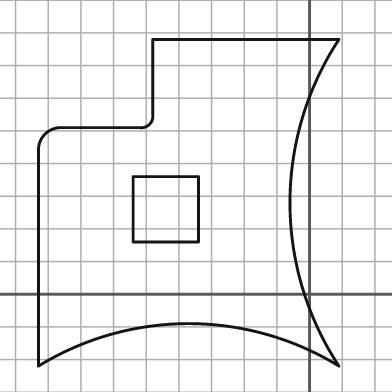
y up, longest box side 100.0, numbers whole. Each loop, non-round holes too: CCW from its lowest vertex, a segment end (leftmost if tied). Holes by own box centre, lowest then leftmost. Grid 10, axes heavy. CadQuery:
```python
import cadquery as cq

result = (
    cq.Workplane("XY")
    .moveTo(-83.0, -22.0)
    .threePointArc((-37.0, -9.0), (9.0, -22.0))
    .threePointArc((-6.0, 28.0), (9.0, 78.0))
    .lineTo(-48.0, 78.0)
    .lineTo(-48.0, 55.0)
    .threePointArc((-49.0, 52.0), (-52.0, 51.0))
    .lineTo(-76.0, 51.0)
    .threePointArc((-81.0, 49.0), (-83.0, 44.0))
    .close()
    .moveTo(-54.0, 16.0)
    .lineTo(-34.0, 16.0)
    .lineTo(-34.0, 36.0)
    .lineTo(-54.0, 36.0)
    .close()
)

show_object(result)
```